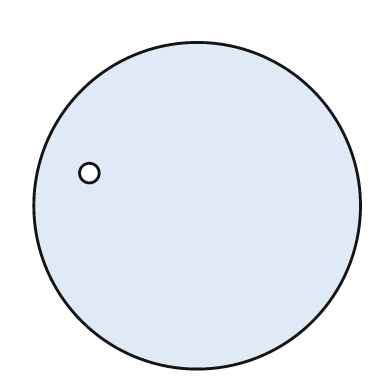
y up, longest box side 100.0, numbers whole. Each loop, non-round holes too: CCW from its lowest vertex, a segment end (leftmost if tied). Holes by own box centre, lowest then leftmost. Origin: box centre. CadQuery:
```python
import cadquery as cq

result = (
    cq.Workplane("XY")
    .moveTo(0.0, 0.0)
    .circle(50.0)
    .moveTo(-33.0, 10.0)
    .circle(3.0)
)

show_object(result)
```